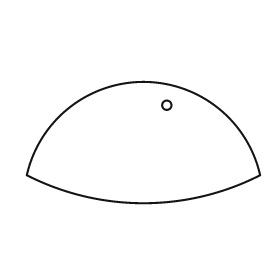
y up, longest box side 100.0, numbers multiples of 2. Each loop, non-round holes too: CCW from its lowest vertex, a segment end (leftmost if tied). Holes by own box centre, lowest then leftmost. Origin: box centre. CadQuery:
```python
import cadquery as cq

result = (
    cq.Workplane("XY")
    .moveTo(-50.0, -14.0)
    .threePointArc((0.0, -26.0), (50.0, -14.0))
    .threePointArc((0.0, 26.0), (-50.0, -14.0))
    .close()
    .moveTo(10.0, 16.0)
    .circle(2.0)
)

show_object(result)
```